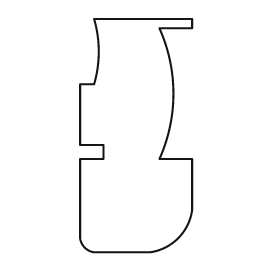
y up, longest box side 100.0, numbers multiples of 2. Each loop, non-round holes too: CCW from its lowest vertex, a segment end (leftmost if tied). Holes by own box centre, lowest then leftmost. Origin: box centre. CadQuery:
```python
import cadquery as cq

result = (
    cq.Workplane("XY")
    .moveTo(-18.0, -50.0)
    .lineTo(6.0, -50.0)
    .threePointArc((18.0, -44.0), (24.0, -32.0))
    .lineTo(24.0, -10.0)
    .lineTo(10.0, -10.0)
    .threePointArc((16.0, 18.0), (10.0, 46.0))
    .lineTo(24.0, 46.0)
    .lineTo(24.0, 50.0)
    .lineTo(-18.0, 50.0)
    .threePointArc((-16.0, 36.0), (-18.0, 22.0))
    .lineTo(-24.0, 22.0)
    .lineTo(-24.0, -4.0)
    .lineTo(-14.0, -4.0)
    .lineTo(-14.0, -10.0)
    .lineTo(-24.0, -10.0)
    .lineTo(-24.0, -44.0)
    .threePointArc((-22.0, -48.0), (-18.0, -50.0))
    .close()
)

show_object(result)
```